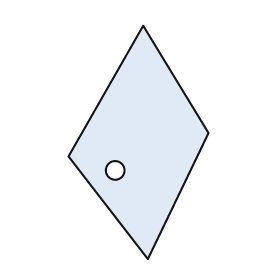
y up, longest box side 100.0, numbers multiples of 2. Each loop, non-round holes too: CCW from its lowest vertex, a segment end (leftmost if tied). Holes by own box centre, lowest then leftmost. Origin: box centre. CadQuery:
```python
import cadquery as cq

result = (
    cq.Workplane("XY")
    .moveTo(4.0, -50.0)
    .lineTo(30.0, 4.0)
    .lineTo(2.0, 50.0)
    .lineTo(-30.0, -6.0)
    .close()
    .moveTo(-10.0, -12.0)
    .circle(4.0)
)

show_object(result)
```